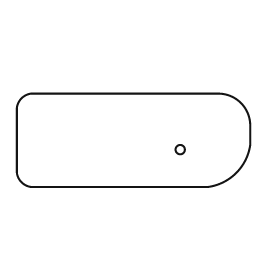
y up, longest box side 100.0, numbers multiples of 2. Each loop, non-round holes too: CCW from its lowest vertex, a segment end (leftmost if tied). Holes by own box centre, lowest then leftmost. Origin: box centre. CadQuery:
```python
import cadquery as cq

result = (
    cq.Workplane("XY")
    .moveTo(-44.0, -20.0)
    .lineTo(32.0, -20.0)
    .threePointArc((44.0, -14.0), (50.0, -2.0))
    .lineTo(50.0, 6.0)
    .threePointArc((46.0, 16.0), (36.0, 20.0))
    .lineTo(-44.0, 20.0)
    .threePointArc((-48.0, 18.0), (-50.0, 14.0))
    .lineTo(-50.0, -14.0)
    .threePointArc((-48.0, -18.0), (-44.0, -20.0))
    .close()
    .moveTo(20.0, -4.0)
    .circle(2.0)
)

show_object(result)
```